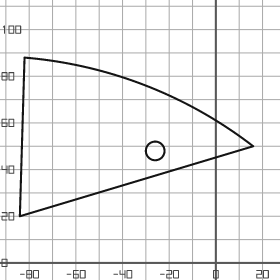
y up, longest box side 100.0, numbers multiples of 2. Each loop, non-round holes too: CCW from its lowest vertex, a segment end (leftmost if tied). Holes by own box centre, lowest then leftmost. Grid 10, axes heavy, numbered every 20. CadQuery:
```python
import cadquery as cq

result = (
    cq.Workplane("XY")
    .moveTo(-84.0, 20.0)
    .lineTo(16.0, 50.0)
    .threePointArc((-30.0, 76.0), (-82.0, 88.0))
    .close()
    .moveTo(-26.0, 48.0)
    .circle(4.0)
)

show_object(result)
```